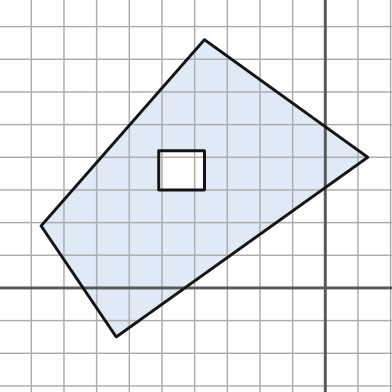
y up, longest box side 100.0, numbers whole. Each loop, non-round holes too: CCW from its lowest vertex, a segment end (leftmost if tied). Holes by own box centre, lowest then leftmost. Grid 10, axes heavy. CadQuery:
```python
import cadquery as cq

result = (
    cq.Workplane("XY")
    .moveTo(-64.0, -15.0)
    .lineTo(13.0, 40.0)
    .lineTo(-37.0, 76.0)
    .lineTo(-87.0, 19.0)
    .close()
    .moveTo(-51.0, 30.0)
    .lineTo(-37.0, 30.0)
    .lineTo(-37.0, 42.0)
    .lineTo(-51.0, 42.0)
    .close()
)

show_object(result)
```